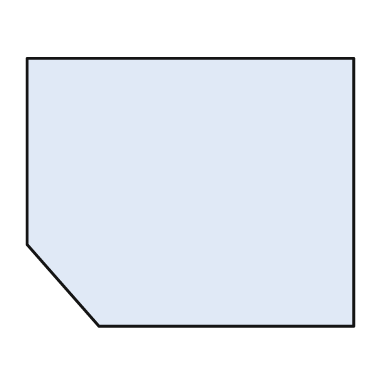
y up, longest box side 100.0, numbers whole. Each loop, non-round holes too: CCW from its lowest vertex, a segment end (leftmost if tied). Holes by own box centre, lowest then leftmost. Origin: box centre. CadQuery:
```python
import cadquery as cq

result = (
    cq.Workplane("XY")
    .moveTo(-28.0, -41.0)
    .lineTo(50.0, -41.0)
    .lineTo(50.0, 41.0)
    .lineTo(-50.0, 41.0)
    .lineTo(-50.0, -16.0)
    .close()
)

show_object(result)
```